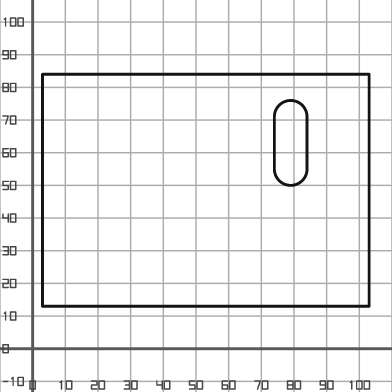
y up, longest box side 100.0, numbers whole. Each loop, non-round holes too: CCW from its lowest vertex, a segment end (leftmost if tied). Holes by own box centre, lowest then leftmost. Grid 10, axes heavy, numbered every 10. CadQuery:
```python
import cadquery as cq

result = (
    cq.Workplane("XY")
    .moveTo(3.0, 13.0)
    .lineTo(103.0, 13.0)
    .lineTo(103.0, 84.0)
    .lineTo(3.0, 84.0)
    .close()
    .moveTo(74.0, 55.0)
    .threePointArc((79.0, 50.0), (84.0, 55.0))
    .lineTo(84.0, 71.0)
    .threePointArc((79.0, 76.0), (74.0, 71.0))
    .close()
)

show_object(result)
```